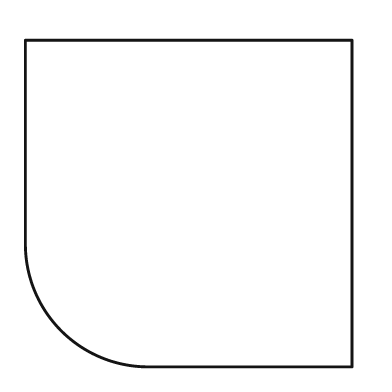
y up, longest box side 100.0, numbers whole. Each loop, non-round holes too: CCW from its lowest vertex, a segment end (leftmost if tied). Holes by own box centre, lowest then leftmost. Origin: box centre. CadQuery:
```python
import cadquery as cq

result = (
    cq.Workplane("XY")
    .moveTo(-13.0, -50.0)
    .lineTo(50.0, -50.0)
    .lineTo(50.0, 50.0)
    .lineTo(-50.0, 50.0)
    .lineTo(-50.0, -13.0)
    .threePointArc((-39.0, -39.0), (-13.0, -50.0))
    .close()
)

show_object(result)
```